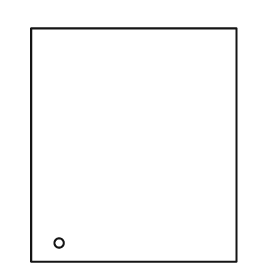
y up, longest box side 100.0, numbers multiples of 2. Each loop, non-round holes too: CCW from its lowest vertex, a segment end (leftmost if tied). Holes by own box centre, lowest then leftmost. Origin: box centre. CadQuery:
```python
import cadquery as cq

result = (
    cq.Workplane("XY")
    .moveTo(-44.0, -50.0)
    .lineTo(44.0, -50.0)
    .lineTo(44.0, 50.0)
    .lineTo(-44.0, 50.0)
    .close()
    .moveTo(-32.0, -42.0)
    .circle(2.0)
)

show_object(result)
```